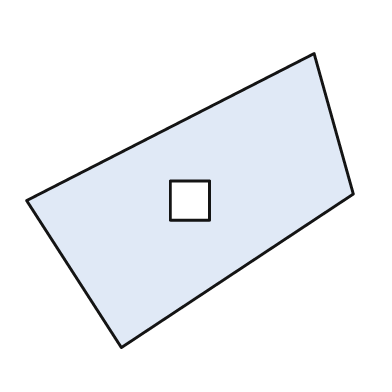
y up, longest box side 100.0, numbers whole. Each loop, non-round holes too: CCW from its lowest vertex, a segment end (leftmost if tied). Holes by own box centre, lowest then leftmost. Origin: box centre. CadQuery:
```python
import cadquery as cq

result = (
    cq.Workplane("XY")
    .moveTo(-21.0, -45.0)
    .lineTo(50.0, 2.0)
    .lineTo(38.0, 45.0)
    .lineTo(-50.0, 0.0)
    .close()
    .moveTo(-6.0, -6.0)
    .lineTo(6.0, -6.0)
    .lineTo(6.0, 6.0)
    .lineTo(-6.0, 6.0)
    .close()
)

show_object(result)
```